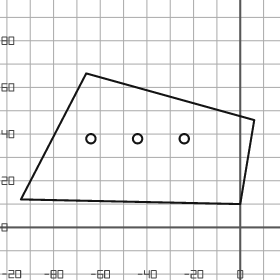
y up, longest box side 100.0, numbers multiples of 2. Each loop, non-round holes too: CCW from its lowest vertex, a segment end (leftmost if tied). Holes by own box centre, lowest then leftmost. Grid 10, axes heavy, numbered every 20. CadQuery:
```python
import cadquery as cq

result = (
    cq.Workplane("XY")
    .moveTo(0.0, 10.0)
    .lineTo(6.0, 46.0)
    .lineTo(-66.0, 66.0)
    .lineTo(-94.0, 12.0)
    .close()
    .moveTo(-64.0, 38.0)
    .circle(2.0)
    .moveTo(-44.0, 38.0)
    .circle(2.0)
    .moveTo(-24.0, 38.0)
    .circle(2.0)
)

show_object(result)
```